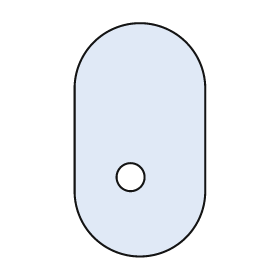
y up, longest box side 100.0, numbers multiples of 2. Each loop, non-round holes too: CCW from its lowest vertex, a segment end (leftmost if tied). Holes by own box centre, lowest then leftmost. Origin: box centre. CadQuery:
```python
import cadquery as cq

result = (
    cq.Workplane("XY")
    .moveTo(-28.0, -22.0)
    .threePointArc((0.0, -50.0), (28.0, -22.0))
    .lineTo(28.0, 22.0)
    .threePointArc((0.0, 50.0), (-28.0, 22.0))
    .close()
    .moveTo(-4.0, -16.0)
    .circle(6.0)
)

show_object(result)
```